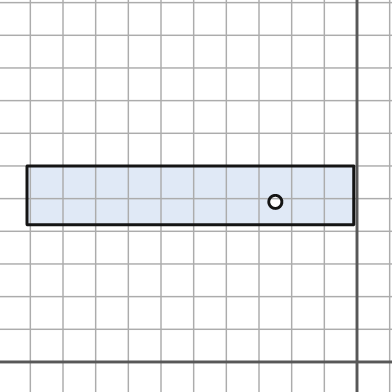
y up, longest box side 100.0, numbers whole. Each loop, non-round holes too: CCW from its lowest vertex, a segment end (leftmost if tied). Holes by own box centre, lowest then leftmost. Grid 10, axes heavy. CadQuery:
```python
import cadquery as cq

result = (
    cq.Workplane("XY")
    .moveTo(-101.0, 42.0)
    .lineTo(-1.0, 42.0)
    .lineTo(-1.0, 60.0)
    .lineTo(-101.0, 60.0)
    .close()
    .moveTo(-25.0, 49.0)
    .circle(2.0)
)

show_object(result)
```